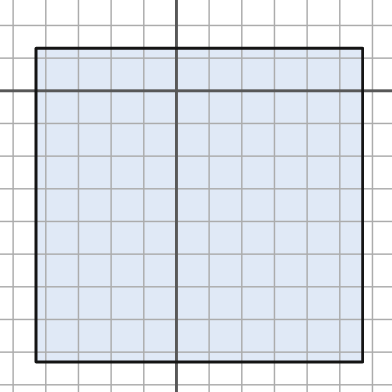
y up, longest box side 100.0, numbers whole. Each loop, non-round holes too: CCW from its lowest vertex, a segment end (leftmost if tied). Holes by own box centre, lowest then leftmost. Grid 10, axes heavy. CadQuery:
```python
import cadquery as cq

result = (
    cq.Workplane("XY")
    .moveTo(-43.0, -83.0)
    .lineTo(57.0, -83.0)
    .lineTo(57.0, 13.0)
    .lineTo(-43.0, 13.0)
    .close()
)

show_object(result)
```